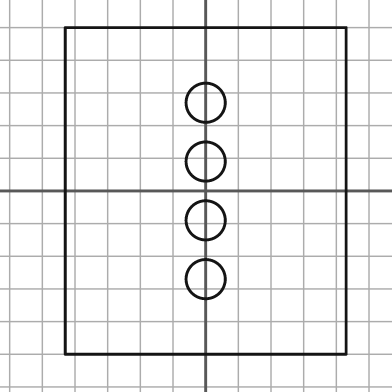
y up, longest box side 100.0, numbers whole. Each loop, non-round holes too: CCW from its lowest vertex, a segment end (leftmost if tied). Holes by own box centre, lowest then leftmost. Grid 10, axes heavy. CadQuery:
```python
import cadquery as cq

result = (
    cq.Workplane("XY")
    .moveTo(-43.0, -50.0)
    .lineTo(43.0, -50.0)
    .lineTo(43.0, 50.0)
    .lineTo(-43.0, 50.0)
    .close()
    .moveTo(0.0, -27.0)
    .circle(6.0)
    .moveTo(0.0, -9.0)
    .circle(6.0)
    .moveTo(0.0, 9.0)
    .circle(6.0)
    .moveTo(0.0, 27.0)
    .circle(6.0)
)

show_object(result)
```